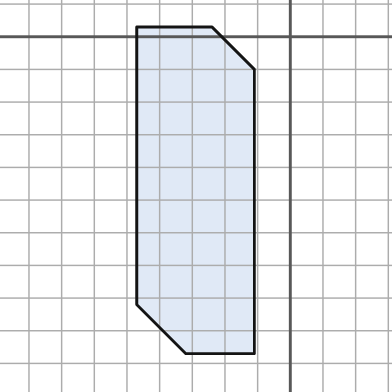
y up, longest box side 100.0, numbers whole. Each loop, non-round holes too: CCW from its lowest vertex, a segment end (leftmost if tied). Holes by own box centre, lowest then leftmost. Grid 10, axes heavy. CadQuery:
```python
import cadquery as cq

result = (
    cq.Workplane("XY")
    .moveTo(-32.0, -97.0)
    .lineTo(-11.0, -97.0)
    .lineTo(-11.0, -10.0)
    .lineTo(-24.0, 3.0)
    .lineTo(-47.0, 3.0)
    .lineTo(-47.0, -82.0)
    .close()
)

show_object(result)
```